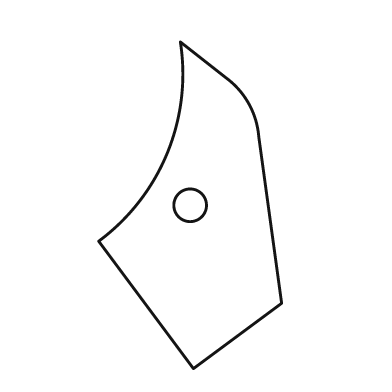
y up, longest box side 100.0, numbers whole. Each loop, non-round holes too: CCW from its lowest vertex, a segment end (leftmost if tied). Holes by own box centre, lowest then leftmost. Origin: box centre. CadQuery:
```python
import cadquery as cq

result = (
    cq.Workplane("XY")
    .moveTo(1.0, -50.0)
    .lineTo(28.0, -30.0)
    .lineTo(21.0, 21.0)
    .threePointArc((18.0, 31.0), (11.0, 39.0))
    .lineTo(-3.0, 50.0)
    .threePointArc((-7.0, 16.0), (-28.0, -11.0))
    .close()
    .moveTo(0.0, 0.0)
    .circle(5.0)
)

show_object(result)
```